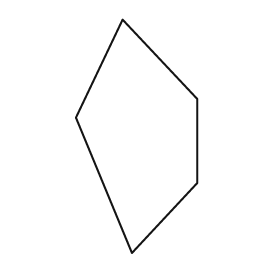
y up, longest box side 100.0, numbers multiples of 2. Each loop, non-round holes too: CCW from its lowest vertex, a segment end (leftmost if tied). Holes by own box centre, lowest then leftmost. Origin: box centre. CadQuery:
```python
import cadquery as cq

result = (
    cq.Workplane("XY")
    .moveTo(-2.0, -50.0)
    .lineTo(26.0, -20.0)
    .lineTo(26.0, 16.0)
    .lineTo(-6.0, 50.0)
    .lineTo(-26.0, 8.0)
    .close()
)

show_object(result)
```